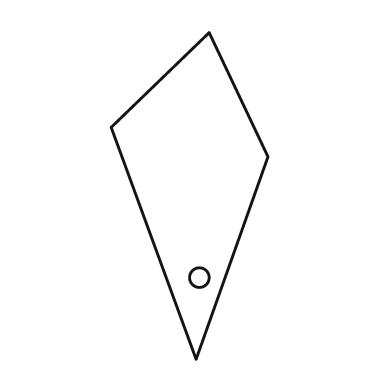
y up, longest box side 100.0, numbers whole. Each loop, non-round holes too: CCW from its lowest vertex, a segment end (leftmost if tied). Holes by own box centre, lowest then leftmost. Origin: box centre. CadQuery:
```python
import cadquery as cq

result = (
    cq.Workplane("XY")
    .moveTo(2.0, -50.0)
    .lineTo(24.0, 12.0)
    .lineTo(6.0, 50.0)
    .lineTo(-24.0, 21.0)
    .close()
    .moveTo(3.0, -25.0)
    .circle(3.0)
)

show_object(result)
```